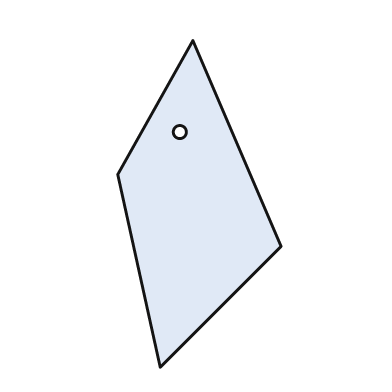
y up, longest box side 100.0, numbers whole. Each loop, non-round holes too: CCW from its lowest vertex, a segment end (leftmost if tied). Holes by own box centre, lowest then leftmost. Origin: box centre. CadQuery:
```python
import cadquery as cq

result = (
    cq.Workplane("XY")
    .moveTo(-12.0, -50.0)
    .lineTo(25.0, -13.0)
    .lineTo(-2.0, 50.0)
    .lineTo(-25.0, 9.0)
    .close()
    .moveTo(-6.0, 22.0)
    .circle(2.0)
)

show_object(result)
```